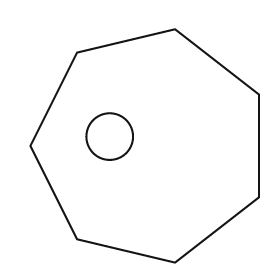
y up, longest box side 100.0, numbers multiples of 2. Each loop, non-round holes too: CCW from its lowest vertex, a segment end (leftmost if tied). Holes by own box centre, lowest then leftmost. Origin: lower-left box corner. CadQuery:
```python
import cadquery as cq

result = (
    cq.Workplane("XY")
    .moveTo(62.0, 0.0)
    .lineTo(98.0, 28.0)
    .lineTo(98.0, 72.0)
    .lineTo(62.0, 100.0)
    .lineTo(20.0, 90.0)
    .lineTo(0.0, 50.0)
    .lineTo(20.0, 10.0)
    .close()
    .moveTo(34.0, 54.0)
    .circle(10.0)
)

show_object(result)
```